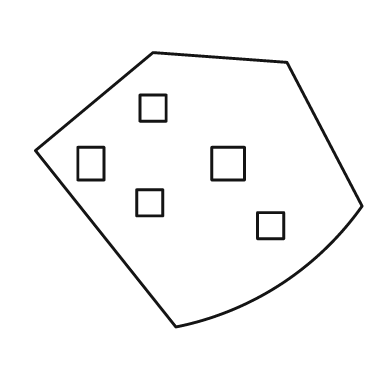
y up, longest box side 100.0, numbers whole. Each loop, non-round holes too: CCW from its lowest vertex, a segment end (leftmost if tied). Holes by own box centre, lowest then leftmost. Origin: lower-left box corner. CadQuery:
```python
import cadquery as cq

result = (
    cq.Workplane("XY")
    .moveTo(43.0, 0.0)
    .threePointArc((75.0, 13.0), (100.0, 37.0))
    .lineTo(77.0, 81.0)
    .lineTo(36.0, 84.0)
    .lineTo(0.0, 54.0)
    .close()
    .moveTo(68.0, 27.0)
    .lineTo(76.0, 27.0)
    .lineTo(76.0, 35.0)
    .lineTo(68.0, 35.0)
    .close()
    .moveTo(31.0, 34.0)
    .lineTo(39.0, 34.0)
    .lineTo(39.0, 42.0)
    .lineTo(31.0, 42.0)
    .close()
    .moveTo(13.0, 45.0)
    .lineTo(21.0, 45.0)
    .lineTo(21.0, 55.0)
    .lineTo(13.0, 55.0)
    .close()
    .moveTo(54.0, 45.0)
    .lineTo(64.0, 45.0)
    .lineTo(64.0, 55.0)
    .lineTo(54.0, 55.0)
    .close()
    .moveTo(32.0, 63.0)
    .lineTo(40.0, 63.0)
    .lineTo(40.0, 71.0)
    .lineTo(32.0, 71.0)
    .close()
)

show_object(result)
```